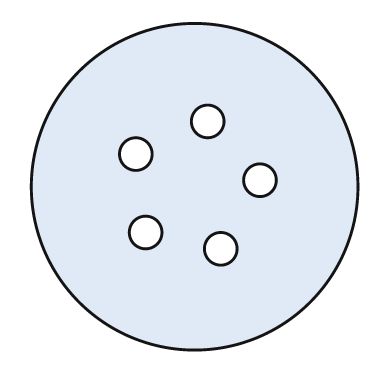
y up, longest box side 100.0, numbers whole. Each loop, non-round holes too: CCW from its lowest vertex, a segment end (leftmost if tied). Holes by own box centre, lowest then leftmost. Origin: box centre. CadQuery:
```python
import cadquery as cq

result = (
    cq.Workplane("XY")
    .moveTo(0.0, 0.0)
    .circle(50.0)
    .moveTo(8.0, -19.0)
    .circle(5.0)
    .moveTo(-15.0, -14.0)
    .circle(5.0)
    .moveTo(20.0, 2.0)
    .circle(5.0)
    .moveTo(-18.0, 10.0)
    .circle(5.0)
    .moveTo(4.0, 20.0)
    .circle(5.0)
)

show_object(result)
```